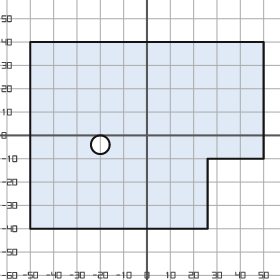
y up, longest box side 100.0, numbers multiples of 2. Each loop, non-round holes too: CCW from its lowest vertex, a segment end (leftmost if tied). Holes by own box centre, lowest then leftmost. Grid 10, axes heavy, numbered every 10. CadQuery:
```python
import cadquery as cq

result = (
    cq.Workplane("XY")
    .moveTo(-50.0, -40.0)
    .lineTo(26.0, -40.0)
    .lineTo(26.0, -10.0)
    .lineTo(50.0, -10.0)
    .lineTo(50.0, 40.0)
    .lineTo(-50.0, 40.0)
    .close()
    .moveTo(-20.0, -4.0)
    .circle(4.0)
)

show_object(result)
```